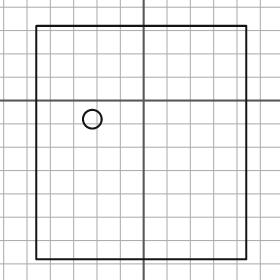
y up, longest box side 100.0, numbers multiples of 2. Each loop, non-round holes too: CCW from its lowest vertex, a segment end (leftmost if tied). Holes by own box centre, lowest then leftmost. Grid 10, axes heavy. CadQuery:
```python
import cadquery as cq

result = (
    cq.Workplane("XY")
    .moveTo(-46.0, -68.0)
    .lineTo(44.0, -68.0)
    .lineTo(44.0, 32.0)
    .lineTo(-46.0, 32.0)
    .close()
    .moveTo(-22.0, -8.0)
    .circle(4.0)
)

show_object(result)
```